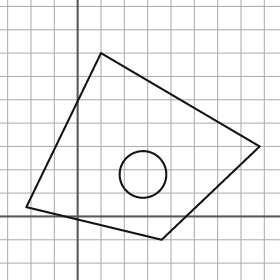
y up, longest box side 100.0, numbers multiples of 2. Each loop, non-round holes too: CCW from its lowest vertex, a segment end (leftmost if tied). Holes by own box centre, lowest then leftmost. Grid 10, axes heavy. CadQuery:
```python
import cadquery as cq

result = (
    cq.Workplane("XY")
    .moveTo(36.0, -10.0)
    .lineTo(78.0, 30.0)
    .lineTo(10.0, 70.0)
    .lineTo(-22.0, 4.0)
    .close()
    .moveTo(28.0, 18.0)
    .circle(10.0)
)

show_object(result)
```